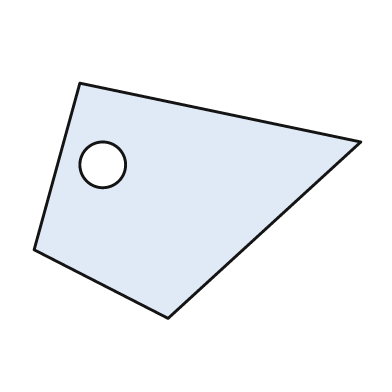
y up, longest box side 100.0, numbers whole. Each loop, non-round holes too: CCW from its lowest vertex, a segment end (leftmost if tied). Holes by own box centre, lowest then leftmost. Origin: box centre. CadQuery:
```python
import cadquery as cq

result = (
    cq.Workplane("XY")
    .moveTo(-9.0, -36.0)
    .lineTo(50.0, 18.0)
    .lineTo(-36.0, 36.0)
    .lineTo(-50.0, -15.0)
    .close()
    .moveTo(-29.0, 11.0)
    .circle(7.0)
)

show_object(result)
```